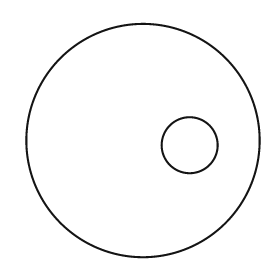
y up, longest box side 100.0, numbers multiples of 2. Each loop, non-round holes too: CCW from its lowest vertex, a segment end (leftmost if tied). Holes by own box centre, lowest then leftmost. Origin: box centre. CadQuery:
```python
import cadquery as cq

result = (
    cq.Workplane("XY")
    .moveTo(0.0, 0.0)
    .circle(50.0)
    .moveTo(20.0, -2.0)
    .circle(12.0)
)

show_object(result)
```